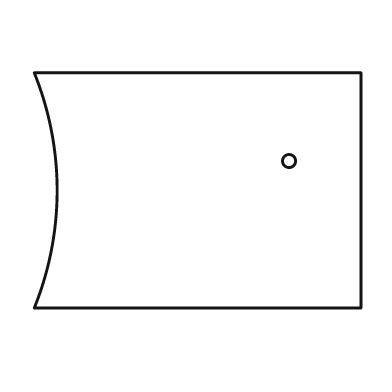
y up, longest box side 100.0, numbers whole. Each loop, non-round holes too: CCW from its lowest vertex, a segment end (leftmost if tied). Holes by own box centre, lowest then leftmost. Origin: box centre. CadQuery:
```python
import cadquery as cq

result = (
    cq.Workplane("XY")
    .moveTo(-50.0, -36.0)
    .lineTo(50.0, -36.0)
    .lineTo(50.0, 36.0)
    .lineTo(-50.0, 36.0)
    .threePointArc((-43.0, 0.0), (-50.0, -36.0))
    .close()
    .moveTo(28.0, 9.0)
    .circle(2.0)
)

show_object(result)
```